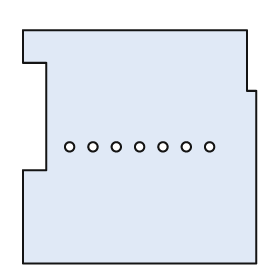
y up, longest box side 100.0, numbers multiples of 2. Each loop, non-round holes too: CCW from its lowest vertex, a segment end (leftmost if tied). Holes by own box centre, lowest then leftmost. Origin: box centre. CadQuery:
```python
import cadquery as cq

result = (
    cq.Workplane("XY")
    .moveTo(-50.0, -50.0)
    .lineTo(50.0, -50.0)
    .lineTo(50.0, 24.0)
    .lineTo(46.0, 24.0)
    .lineTo(46.0, 50.0)
    .lineTo(-50.0, 50.0)
    .lineTo(-50.0, 36.0)
    .lineTo(-40.0, 36.0)
    .lineTo(-40.0, -10.0)
    .lineTo(-50.0, -10.0)
    .close()
    .moveTo(-30.0, 0.0)
    .circle(2.0)
    .moveTo(-20.0, 0.0)
    .circle(2.0)
    .moveTo(-10.0, 0.0)
    .circle(2.0)
    .moveTo(0.0, 0.0)
    .circle(2.0)
    .moveTo(10.0, 0.0)
    .circle(2.0)
    .moveTo(20.0, 0.0)
    .circle(2.0)
    .moveTo(30.0, 0.0)
    .circle(2.0)
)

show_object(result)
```